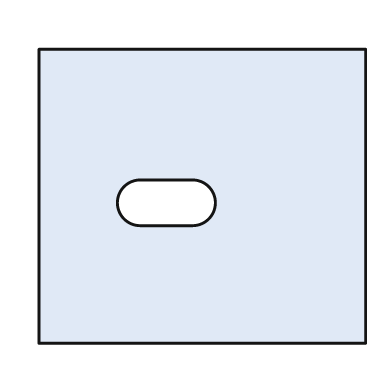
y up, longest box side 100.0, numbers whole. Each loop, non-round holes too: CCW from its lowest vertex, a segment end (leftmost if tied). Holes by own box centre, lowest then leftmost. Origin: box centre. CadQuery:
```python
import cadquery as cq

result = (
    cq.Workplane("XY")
    .moveTo(-50.0, -45.0)
    .lineTo(50.0, -45.0)
    .lineTo(50.0, 45.0)
    .lineTo(-50.0, 45.0)
    .close()
    .moveTo(-19.0, -9.0)
    .lineTo(-3.0, -9.0)
    .threePointArc((4.0, -2.0), (-3.0, 5.0))
    .lineTo(-19.0, 5.0)
    .threePointArc((-26.0, -2.0), (-19.0, -9.0))
    .close()
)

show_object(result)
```